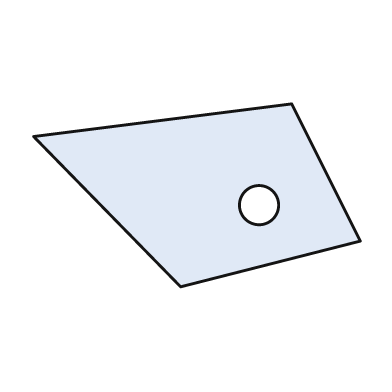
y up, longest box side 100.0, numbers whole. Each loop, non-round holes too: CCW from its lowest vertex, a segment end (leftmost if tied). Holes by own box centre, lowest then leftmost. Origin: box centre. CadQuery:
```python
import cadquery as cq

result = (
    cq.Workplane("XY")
    .moveTo(-5.0, -28.0)
    .lineTo(50.0, -14.0)
    .lineTo(29.0, 28.0)
    .lineTo(-50.0, 18.0)
    .close()
    .moveTo(19.0, -3.0)
    .circle(6.0)
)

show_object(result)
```